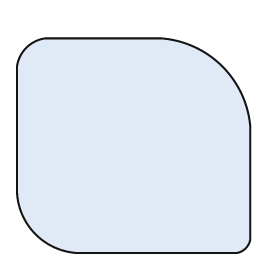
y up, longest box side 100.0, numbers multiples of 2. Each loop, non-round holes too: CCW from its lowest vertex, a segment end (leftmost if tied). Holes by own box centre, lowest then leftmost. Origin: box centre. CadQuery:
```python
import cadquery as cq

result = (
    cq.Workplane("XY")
    .moveTo(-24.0, -46.0)
    .lineTo(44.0, -46.0)
    .threePointArc((48.0, -44.0), (50.0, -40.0))
    .lineTo(50.0, 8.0)
    .threePointArc((38.0, 34.0), (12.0, 46.0))
    .lineTo(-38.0, 46.0)
    .threePointArc((-46.0, 42.0), (-50.0, 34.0))
    .lineTo(-50.0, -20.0)
    .threePointArc((-42.0, -38.0), (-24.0, -46.0))
    .close()
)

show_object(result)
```